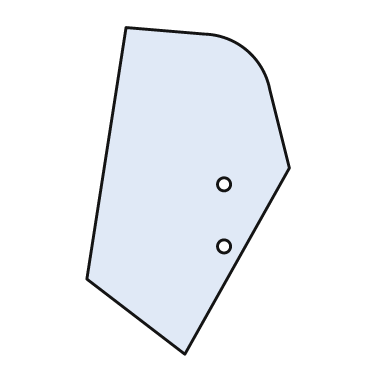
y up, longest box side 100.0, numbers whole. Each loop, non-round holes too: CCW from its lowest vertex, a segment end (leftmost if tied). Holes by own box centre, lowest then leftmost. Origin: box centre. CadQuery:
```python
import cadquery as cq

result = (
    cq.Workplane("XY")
    .moveTo(-1.0, -50.0)
    .lineTo(31.0, 7.0)
    .lineTo(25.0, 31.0)
    .threePointArc((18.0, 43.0), (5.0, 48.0))
    .lineTo(-19.0, 50.0)
    .lineTo(-31.0, -27.0)
    .close()
    .moveTo(11.0, -17.0)
    .circle(2.0)
    .moveTo(11.0, 2.0)
    .circle(2.0)
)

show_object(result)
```